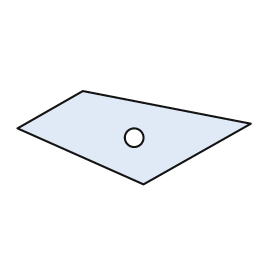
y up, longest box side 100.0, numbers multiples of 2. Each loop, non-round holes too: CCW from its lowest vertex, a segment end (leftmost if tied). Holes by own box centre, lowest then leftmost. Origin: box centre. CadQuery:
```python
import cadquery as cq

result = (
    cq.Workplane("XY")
    .moveTo(4.0, -20.0)
    .lineTo(50.0, 6.0)
    .lineTo(-22.0, 20.0)
    .lineTo(-50.0, 4.0)
    .close()
    .moveTo(0.0, 0.0)
    .circle(4.0)
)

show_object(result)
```